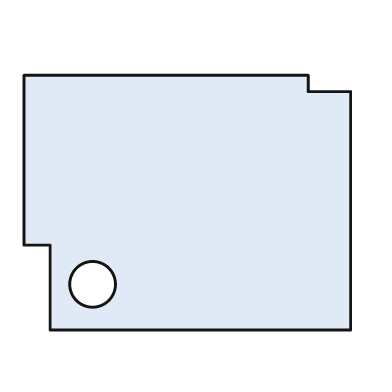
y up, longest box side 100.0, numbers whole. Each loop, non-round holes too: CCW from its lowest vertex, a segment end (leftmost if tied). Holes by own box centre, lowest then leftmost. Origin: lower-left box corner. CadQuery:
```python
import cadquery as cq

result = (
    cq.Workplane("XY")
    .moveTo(8.0, 0.0)
    .lineTo(100.0, 0.0)
    .lineTo(100.0, 73.0)
    .lineTo(87.0, 73.0)
    .lineTo(87.0, 78.0)
    .lineTo(0.0, 78.0)
    .lineTo(0.0, 26.0)
    .lineTo(8.0, 26.0)
    .close()
    .moveTo(21.0, 14.0)
    .circle(7.0)
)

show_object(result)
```